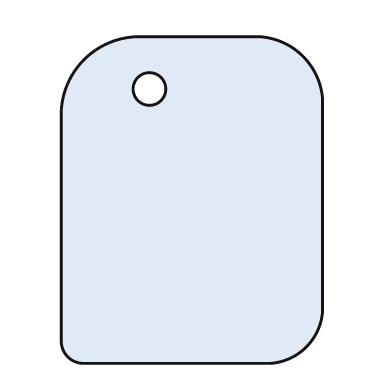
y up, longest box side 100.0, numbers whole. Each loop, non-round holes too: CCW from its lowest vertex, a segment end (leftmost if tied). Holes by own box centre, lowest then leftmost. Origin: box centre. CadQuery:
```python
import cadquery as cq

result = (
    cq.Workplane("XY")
    .moveTo(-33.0, -50.0)
    .lineTo(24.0, -50.0)
    .threePointArc((35.0, -45.0), (40.0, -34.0))
    .lineTo(40.0, 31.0)
    .threePointArc((34.0, 44.0), (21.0, 50.0))
    .lineTo(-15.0, 50.0)
    .threePointArc((-33.0, 43.0), (-40.0, 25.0))
    .lineTo(-40.0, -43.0)
    .threePointArc((-38.0, -48.0), (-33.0, -50.0))
    .close()
    .moveTo(-13.0, 34.0)
    .circle(5.0)
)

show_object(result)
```